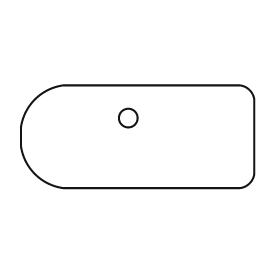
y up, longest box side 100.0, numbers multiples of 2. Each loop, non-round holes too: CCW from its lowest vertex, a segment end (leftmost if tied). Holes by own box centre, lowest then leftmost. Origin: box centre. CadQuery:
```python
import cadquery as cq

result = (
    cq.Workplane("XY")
    .moveTo(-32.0, -22.0)
    .lineTo(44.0, -22.0)
    .threePointArc((48.0, -20.0), (50.0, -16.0))
    .lineTo(50.0, 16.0)
    .threePointArc((48.0, 20.0), (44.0, 22.0))
    .lineTo(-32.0, 22.0)
    .threePointArc((-44.0, 16.0), (-50.0, 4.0))
    .lineTo(-50.0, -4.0)
    .threePointArc((-44.0, -16.0), (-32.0, -22.0))
    .close()
    .moveTo(-4.0, 8.0)
    .circle(4.0)
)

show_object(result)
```